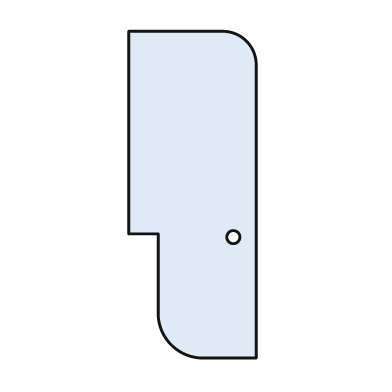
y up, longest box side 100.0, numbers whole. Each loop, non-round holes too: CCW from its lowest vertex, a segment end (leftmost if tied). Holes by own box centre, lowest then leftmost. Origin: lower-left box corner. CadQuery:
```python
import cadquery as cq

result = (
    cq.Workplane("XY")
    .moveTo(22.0, 0.0)
    .lineTo(39.0, 0.0)
    .lineTo(39.0, 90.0)
    .threePointArc((36.0, 97.0), (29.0, 100.0))
    .lineTo(0.0, 100.0)
    .lineTo(0.0, 38.0)
    .lineTo(9.0, 38.0)
    .lineTo(9.0, 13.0)
    .threePointArc((13.0, 4.0), (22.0, 0.0))
    .close()
    .moveTo(32.0, 37.0)
    .circle(2.0)
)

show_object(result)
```